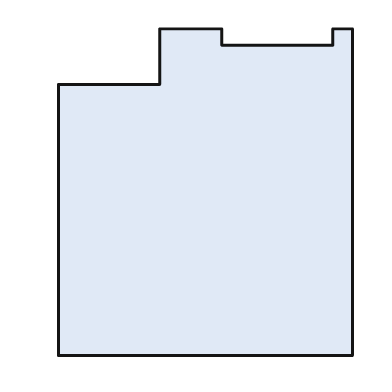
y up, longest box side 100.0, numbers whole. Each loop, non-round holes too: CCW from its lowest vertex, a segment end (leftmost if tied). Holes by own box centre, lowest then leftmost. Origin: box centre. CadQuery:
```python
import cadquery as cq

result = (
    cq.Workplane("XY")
    .moveTo(-45.0, -50.0)
    .lineTo(45.0, -50.0)
    .lineTo(45.0, 50.0)
    .lineTo(39.0, 50.0)
    .lineTo(39.0, 45.0)
    .lineTo(5.0, 45.0)
    .lineTo(5.0, 50.0)
    .lineTo(-14.0, 50.0)
    .lineTo(-14.0, 33.0)
    .lineTo(-45.0, 33.0)
    .close()
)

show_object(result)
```